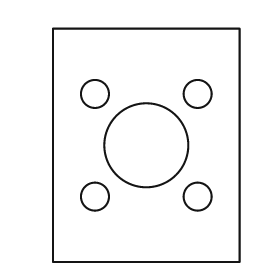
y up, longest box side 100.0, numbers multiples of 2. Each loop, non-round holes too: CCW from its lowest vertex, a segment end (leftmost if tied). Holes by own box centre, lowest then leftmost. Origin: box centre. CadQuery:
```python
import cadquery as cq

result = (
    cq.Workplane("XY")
    .moveTo(-40.0, -50.0)
    .lineTo(40.0, -50.0)
    .lineTo(40.0, 50.0)
    .lineTo(-40.0, 50.0)
    .close()
    .moveTo(-22.0, -22.0)
    .circle(6.0)
    .moveTo(22.0, -22.0)
    .circle(6.0)
    .moveTo(0.0, 0.0)
    .circle(18.0)
    .moveTo(-22.0, 22.0)
    .circle(6.0)
    .moveTo(22.0, 22.0)
    .circle(6.0)
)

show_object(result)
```